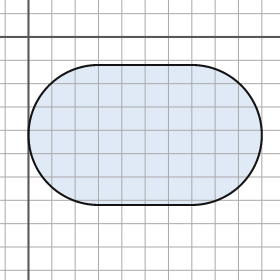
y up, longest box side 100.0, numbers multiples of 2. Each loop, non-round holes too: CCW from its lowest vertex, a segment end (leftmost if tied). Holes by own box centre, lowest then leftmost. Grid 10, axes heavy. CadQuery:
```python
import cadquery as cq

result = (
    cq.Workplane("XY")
    .moveTo(30.0, -72.0)
    .lineTo(70.0, -72.0)
    .threePointArc((100.0, -42.0), (70.0, -12.0))
    .lineTo(30.0, -12.0)
    .threePointArc((0.0, -42.0), (30.0, -72.0))
    .close()
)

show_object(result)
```